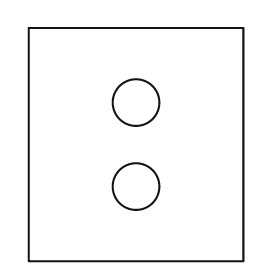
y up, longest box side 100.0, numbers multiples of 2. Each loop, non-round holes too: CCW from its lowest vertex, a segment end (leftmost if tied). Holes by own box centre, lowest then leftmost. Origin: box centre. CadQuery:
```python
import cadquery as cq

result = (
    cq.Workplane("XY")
    .moveTo(-46.0, -50.0)
    .lineTo(46.0, -50.0)
    .lineTo(46.0, 50.0)
    .lineTo(-46.0, 50.0)
    .close()
    .moveTo(0.0, -18.0)
    .circle(10.0)
    .moveTo(0.0, 18.0)
    .circle(10.0)
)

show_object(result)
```